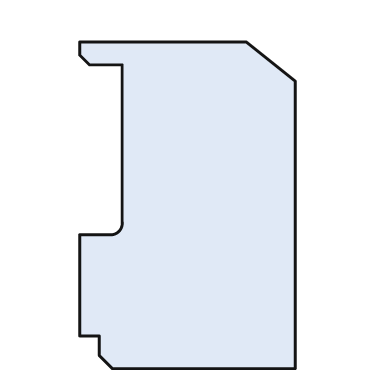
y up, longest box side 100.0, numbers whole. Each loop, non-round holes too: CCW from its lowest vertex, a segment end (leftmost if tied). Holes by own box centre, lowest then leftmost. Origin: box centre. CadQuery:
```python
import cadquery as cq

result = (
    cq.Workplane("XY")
    .moveTo(-23.0, -50.0)
    .lineTo(33.0, -50.0)
    .lineTo(33.0, 38.0)
    .lineTo(18.0, 50.0)
    .lineTo(-33.0, 50.0)
    .lineTo(-33.0, 46.0)
    .lineTo(-30.0, 43.0)
    .lineTo(-20.0, 43.0)
    .lineTo(-20.0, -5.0)
    .threePointArc((-21.0, -8.0), (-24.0, -9.0))
    .lineTo(-33.0, -9.0)
    .lineTo(-33.0, -40.0)
    .lineTo(-27.0, -40.0)
    .lineTo(-27.0, -46.0)
    .close()
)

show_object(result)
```